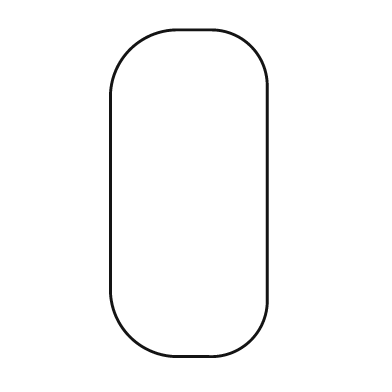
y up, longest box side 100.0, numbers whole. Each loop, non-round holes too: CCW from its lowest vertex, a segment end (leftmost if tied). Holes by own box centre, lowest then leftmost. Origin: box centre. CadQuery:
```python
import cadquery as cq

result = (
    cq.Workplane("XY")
    .moveTo(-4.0, -50.0)
    .lineTo(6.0, -50.0)
    .threePointArc((19.0, -45.0), (24.0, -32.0))
    .lineTo(24.0, 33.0)
    .threePointArc((19.0, 45.0), (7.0, 50.0))
    .lineTo(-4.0, 50.0)
    .threePointArc((-18.0, 44.0), (-24.0, 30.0))
    .lineTo(-24.0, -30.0)
    .threePointArc((-18.0, -44.0), (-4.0, -50.0))
    .close()
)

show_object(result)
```